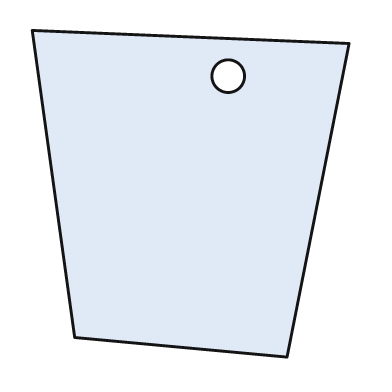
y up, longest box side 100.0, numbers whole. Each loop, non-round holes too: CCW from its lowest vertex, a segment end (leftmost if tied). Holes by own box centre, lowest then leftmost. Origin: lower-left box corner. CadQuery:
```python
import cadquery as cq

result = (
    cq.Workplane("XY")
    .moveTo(78.0, 0.0)
    .lineTo(97.0, 96.0)
    .lineTo(0.0, 100.0)
    .lineTo(13.0, 6.0)
    .close()
    .moveTo(60.0, 86.0)
    .circle(5.0)
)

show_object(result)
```